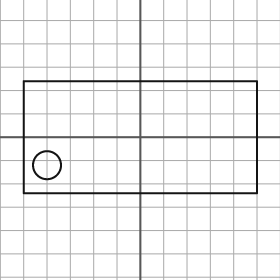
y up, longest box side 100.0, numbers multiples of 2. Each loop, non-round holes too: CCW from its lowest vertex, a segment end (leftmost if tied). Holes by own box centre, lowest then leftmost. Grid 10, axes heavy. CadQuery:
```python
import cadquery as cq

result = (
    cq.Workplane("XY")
    .moveTo(-50.0, -24.0)
    .lineTo(50.0, -24.0)
    .lineTo(50.0, 24.0)
    .lineTo(-50.0, 24.0)
    .close()
    .moveTo(-40.0, -12.0)
    .circle(6.0)
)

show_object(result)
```